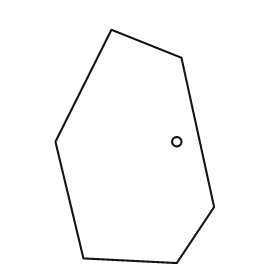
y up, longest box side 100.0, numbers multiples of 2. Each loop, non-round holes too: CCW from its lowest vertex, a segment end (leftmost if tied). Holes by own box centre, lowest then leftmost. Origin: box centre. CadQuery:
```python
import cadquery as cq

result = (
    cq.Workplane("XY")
    .moveTo(18.0, -50.0)
    .lineTo(34.0, -26.0)
    .lineTo(20.0, 38.0)
    .lineTo(-10.0, 50.0)
    .lineTo(-34.0, 2.0)
    .lineTo(-22.0, -48.0)
    .close()
    .moveTo(18.0, 2.0)
    .circle(2.0)
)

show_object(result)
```